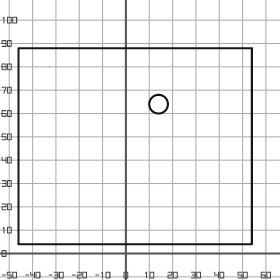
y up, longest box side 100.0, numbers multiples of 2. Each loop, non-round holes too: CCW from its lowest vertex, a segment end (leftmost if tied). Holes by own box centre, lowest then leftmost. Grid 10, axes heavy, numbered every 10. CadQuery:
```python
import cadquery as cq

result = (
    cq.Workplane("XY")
    .moveTo(-46.0, 4.0)
    .lineTo(54.0, 4.0)
    .lineTo(54.0, 88.0)
    .lineTo(-46.0, 88.0)
    .close()
    .moveTo(14.0, 64.0)
    .circle(4.0)
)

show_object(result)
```